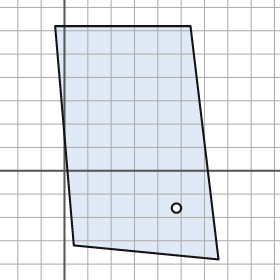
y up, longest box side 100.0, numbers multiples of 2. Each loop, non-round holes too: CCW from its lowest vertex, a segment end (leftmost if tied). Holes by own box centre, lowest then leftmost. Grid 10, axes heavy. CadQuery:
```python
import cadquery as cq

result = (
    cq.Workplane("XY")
    .moveTo(66.0, -38.0)
    .lineTo(54.0, 62.0)
    .lineTo(-4.0, 62.0)
    .lineTo(4.0, -32.0)
    .close()
    .moveTo(48.0, -16.0)
    .circle(2.0)
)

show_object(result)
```